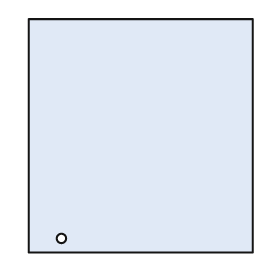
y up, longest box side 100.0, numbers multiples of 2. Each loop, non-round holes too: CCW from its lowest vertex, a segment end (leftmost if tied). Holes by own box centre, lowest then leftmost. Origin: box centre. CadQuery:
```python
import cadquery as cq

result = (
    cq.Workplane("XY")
    .moveTo(-48.0, -50.0)
    .lineTo(48.0, -50.0)
    .lineTo(48.0, 50.0)
    .lineTo(-48.0, 50.0)
    .close()
    .moveTo(-34.0, -44.0)
    .circle(2.0)
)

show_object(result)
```